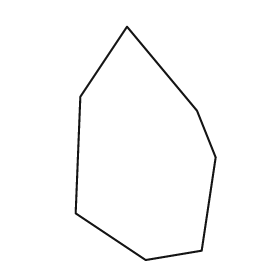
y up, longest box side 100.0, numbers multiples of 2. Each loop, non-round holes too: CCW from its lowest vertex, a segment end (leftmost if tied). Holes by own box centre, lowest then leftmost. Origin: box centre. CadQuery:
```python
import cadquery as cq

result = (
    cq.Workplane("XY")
    .moveTo(0.0, -50.0)
    .lineTo(24.0, -46.0)
    .lineTo(30.0, -6.0)
    .lineTo(22.0, 14.0)
    .lineTo(-8.0, 50.0)
    .lineTo(-28.0, 20.0)
    .lineTo(-30.0, -30.0)
    .close()
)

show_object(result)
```